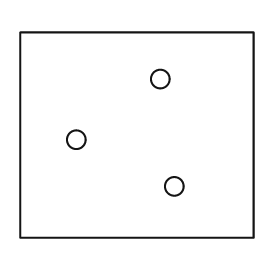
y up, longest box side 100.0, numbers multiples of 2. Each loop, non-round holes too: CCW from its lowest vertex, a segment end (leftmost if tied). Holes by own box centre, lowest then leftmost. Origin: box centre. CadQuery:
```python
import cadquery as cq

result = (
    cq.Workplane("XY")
    .moveTo(-50.0, -44.0)
    .lineTo(50.0, -44.0)
    .lineTo(50.0, 44.0)
    .lineTo(-50.0, 44.0)
    .close()
    .moveTo(16.0, -22.0)
    .circle(4.0)
    .moveTo(-26.0, -2.0)
    .circle(4.0)
    .moveTo(10.0, 24.0)
    .circle(4.0)
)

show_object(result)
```